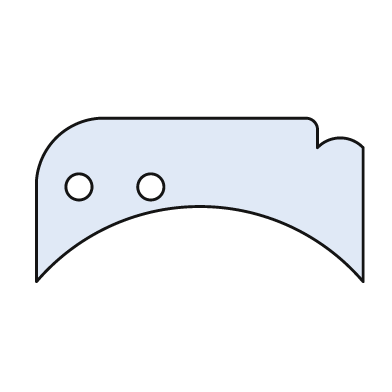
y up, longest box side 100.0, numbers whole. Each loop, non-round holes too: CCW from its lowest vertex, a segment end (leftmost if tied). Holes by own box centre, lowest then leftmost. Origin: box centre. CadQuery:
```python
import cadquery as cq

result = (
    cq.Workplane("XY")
    .moveTo(-50.0, -25.0)
    .threePointArc((0.0, -2.0), (50.0, -25.0))
    .lineTo(50.0, 16.0)
    .threePointArc((43.0, 19.0), (36.0, 16.0))
    .lineTo(36.0, 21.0)
    .threePointArc((35.0, 24.0), (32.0, 25.0))
    .lineTo(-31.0, 25.0)
    .threePointArc((-44.0, 19.0), (-50.0, 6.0))
    .close()
    .moveTo(-37.0, 4.0)
    .circle(4.0)
    .moveTo(-15.0, 4.0)
    .circle(4.0)
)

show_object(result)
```